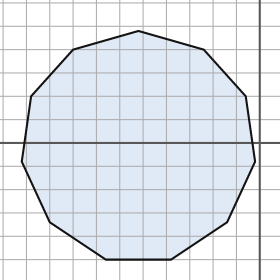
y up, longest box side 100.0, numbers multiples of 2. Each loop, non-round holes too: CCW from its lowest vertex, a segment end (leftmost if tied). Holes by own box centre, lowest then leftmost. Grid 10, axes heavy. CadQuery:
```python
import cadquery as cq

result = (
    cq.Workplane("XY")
    .moveTo(-66.0, -50.0)
    .lineTo(-38.0, -50.0)
    .lineTo(-14.0, -34.0)
    .lineTo(-2.0, -8.0)
    .lineTo(-6.0, 20.0)
    .lineTo(-24.0, 40.0)
    .lineTo(-52.0, 48.0)
    .lineTo(-80.0, 40.0)
    .lineTo(-98.0, 20.0)
    .lineTo(-102.0, -8.0)
    .lineTo(-90.0, -34.0)
    .close()
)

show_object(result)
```